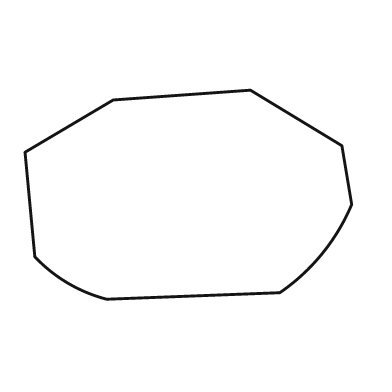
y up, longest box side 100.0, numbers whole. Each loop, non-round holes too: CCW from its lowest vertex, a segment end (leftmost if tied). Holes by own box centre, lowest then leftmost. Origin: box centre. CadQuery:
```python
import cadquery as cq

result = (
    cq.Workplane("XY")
    .moveTo(-25.0, -32.0)
    .lineTo(28.0, -30.0)
    .threePointArc((41.0, -18.0), (50.0, -3.0))
    .lineTo(47.0, 15.0)
    .lineTo(19.0, 32.0)
    .lineTo(-23.0, 29.0)
    .lineTo(-50.0, 13.0)
    .lineTo(-47.0, -19.0)
    .threePointArc((-37.0, -27.0), (-25.0, -32.0))
    .close()
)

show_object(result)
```